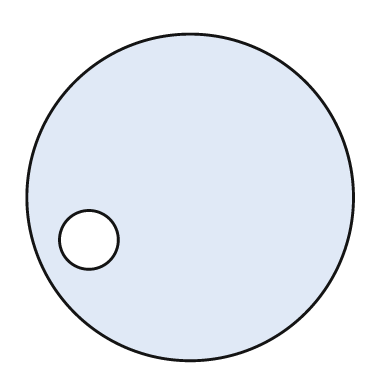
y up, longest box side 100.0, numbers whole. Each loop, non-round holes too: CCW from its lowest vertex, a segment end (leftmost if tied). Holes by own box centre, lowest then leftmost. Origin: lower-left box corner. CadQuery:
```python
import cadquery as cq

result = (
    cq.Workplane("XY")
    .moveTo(50.0, 50.0)
    .circle(50.0)
    .moveTo(19.0, 37.0)
    .circle(9.0)
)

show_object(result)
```